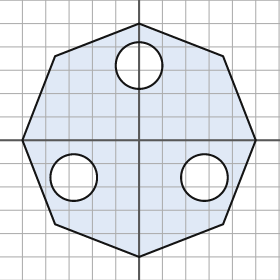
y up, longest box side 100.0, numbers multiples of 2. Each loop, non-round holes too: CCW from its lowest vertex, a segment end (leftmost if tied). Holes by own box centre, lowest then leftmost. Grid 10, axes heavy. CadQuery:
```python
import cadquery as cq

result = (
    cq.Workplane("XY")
    .moveTo(0.0, -50.0)
    .lineTo(36.0, -36.0)
    .lineTo(50.0, 0.0)
    .lineTo(36.0, 36.0)
    .lineTo(0.0, 50.0)
    .lineTo(-36.0, 36.0)
    .lineTo(-50.0, 0.0)
    .lineTo(-36.0, -36.0)
    .close()
    .moveTo(-28.0, -16.0)
    .circle(10.0)
    .moveTo(28.0, -16.0)
    .circle(10.0)
    .moveTo(0.0, 32.0)
    .circle(10.0)
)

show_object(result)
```